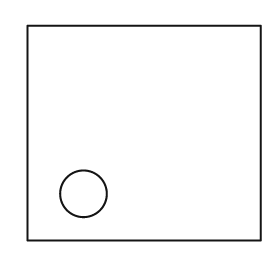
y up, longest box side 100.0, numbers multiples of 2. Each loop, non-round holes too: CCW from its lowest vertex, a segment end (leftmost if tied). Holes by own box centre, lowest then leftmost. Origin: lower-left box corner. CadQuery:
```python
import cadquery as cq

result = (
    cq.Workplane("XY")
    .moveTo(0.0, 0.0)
    .lineTo(100.0, 0.0)
    .lineTo(100.0, 92.0)
    .lineTo(0.0, 92.0)
    .close()
    .moveTo(24.0, 20.0)
    .circle(10.0)
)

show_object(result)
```